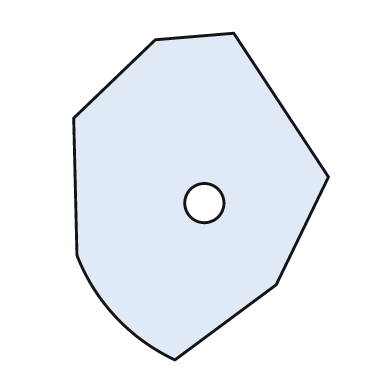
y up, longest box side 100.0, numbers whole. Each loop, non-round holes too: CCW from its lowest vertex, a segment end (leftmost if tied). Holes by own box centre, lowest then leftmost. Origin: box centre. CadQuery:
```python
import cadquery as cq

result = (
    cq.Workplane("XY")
    .moveTo(-8.0, -50.0)
    .lineTo(23.0, -27.0)
    .lineTo(39.0, 6.0)
    .lineTo(10.0, 50.0)
    .lineTo(-14.0, 48.0)
    .lineTo(-39.0, 24.0)
    .lineTo(-38.0, -18.0)
    .threePointArc((-26.0, -37.0), (-8.0, -50.0))
    .close()
    .moveTo(1.0, -2.0)
    .circle(6.0)
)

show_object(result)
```